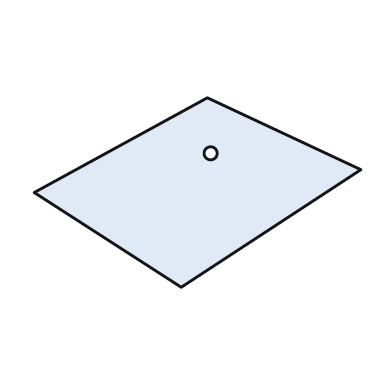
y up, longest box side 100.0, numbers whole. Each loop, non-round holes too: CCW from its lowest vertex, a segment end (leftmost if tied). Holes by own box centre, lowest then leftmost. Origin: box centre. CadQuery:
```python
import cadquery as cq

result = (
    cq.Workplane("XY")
    .moveTo(-5.0, -29.0)
    .lineTo(50.0, 7.0)
    .lineTo(3.0, 29.0)
    .lineTo(-50.0, 0.0)
    .close()
    .moveTo(4.0, 12.0)
    .circle(2.0)
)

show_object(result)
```